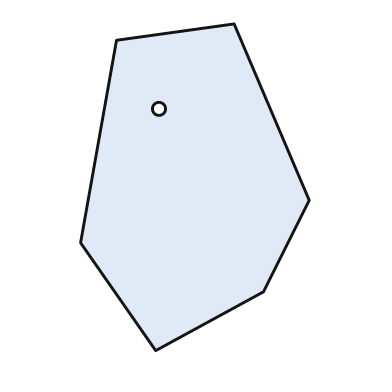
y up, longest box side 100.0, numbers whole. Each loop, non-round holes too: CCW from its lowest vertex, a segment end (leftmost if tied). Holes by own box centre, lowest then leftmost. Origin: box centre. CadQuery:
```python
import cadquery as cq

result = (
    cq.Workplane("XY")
    .moveTo(-12.0, -50.0)
    .lineTo(21.0, -32.0)
    .lineTo(35.0, -4.0)
    .lineTo(12.0, 50.0)
    .lineTo(-24.0, 45.0)
    .lineTo(-35.0, -17.0)
    .close()
    .moveTo(-11.0, 24.0)
    .circle(2.0)
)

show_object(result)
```